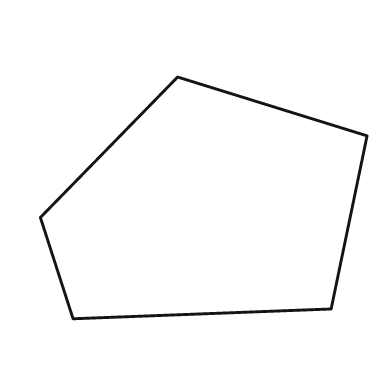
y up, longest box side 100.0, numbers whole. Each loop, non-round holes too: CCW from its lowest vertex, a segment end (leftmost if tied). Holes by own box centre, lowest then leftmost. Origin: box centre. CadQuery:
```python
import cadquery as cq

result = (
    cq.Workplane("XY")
    .moveTo(-40.0, -37.0)
    .lineTo(39.0, -34.0)
    .lineTo(50.0, 19.0)
    .lineTo(-8.0, 37.0)
    .lineTo(-50.0, -6.0)
    .close()
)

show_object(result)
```